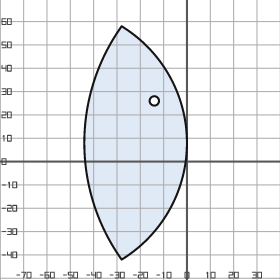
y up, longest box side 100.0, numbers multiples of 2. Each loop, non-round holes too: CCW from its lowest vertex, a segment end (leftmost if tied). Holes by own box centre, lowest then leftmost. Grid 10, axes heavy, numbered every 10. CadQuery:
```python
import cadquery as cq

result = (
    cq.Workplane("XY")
    .moveTo(-28.0, -42.0)
    .threePointArc((0.0, 8.0), (-28.0, 58.0))
    .threePointArc((-44.0, 8.0), (-28.0, -42.0))
    .close()
    .moveTo(-14.0, 26.0)
    .circle(2.0)
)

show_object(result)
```